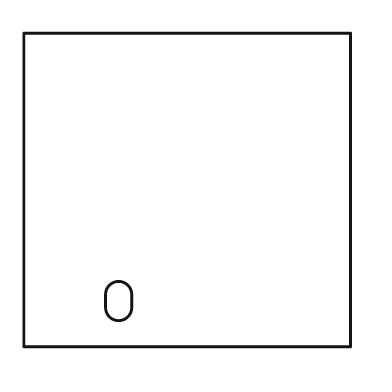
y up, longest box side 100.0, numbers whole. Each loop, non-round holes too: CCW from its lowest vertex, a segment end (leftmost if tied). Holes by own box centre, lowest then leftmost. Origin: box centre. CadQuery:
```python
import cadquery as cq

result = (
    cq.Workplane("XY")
    .moveTo(-50.0, -48.0)
    .lineTo(50.0, -48.0)
    .lineTo(50.0, 48.0)
    .lineTo(-50.0, 48.0)
    .close()
    .moveTo(-25.0, -36.0)
    .threePointArc((-21.0, -40.0), (-17.0, -36.0))
    .lineTo(-17.0, -32.0)
    .threePointArc((-21.0, -28.0), (-25.0, -32.0))
    .close()
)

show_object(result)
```